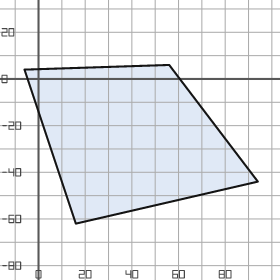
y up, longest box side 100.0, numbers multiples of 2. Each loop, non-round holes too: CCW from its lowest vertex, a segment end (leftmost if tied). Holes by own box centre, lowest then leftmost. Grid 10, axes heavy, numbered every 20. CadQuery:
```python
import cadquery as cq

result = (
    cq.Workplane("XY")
    .moveTo(16.0, -62.0)
    .lineTo(94.0, -44.0)
    .lineTo(56.0, 6.0)
    .lineTo(-6.0, 4.0)
    .close()
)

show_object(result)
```